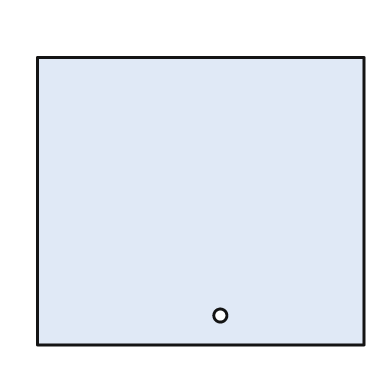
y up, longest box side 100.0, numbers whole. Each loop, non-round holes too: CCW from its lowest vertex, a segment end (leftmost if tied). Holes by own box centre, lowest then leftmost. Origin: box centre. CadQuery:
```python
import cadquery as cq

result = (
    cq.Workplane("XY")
    .moveTo(-50.0, -44.0)
    .lineTo(50.0, -44.0)
    .lineTo(50.0, 44.0)
    .lineTo(-50.0, 44.0)
    .close()
    .moveTo(6.0, -35.0)
    .circle(2.0)
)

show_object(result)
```